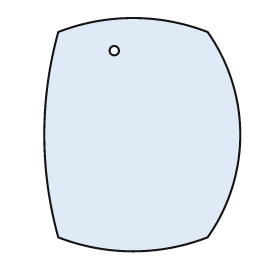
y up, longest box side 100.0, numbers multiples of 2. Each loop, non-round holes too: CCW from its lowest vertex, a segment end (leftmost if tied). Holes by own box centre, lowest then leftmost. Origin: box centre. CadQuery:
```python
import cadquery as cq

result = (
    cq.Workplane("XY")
    .moveTo(-36.0, -44.0)
    .threePointArc((-4.0, -50.0), (28.0, -44.0))
    .threePointArc((42.0, 0.0), (28.0, 44.0))
    .threePointArc((-4.0, 50.0), (-36.0, 44.0))
    .threePointArc((-42.0, 0.0), (-36.0, -44.0))
    .close()
    .moveTo(-12.0, 36.0)
    .circle(2.0)
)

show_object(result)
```